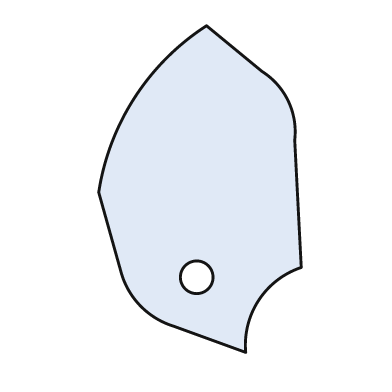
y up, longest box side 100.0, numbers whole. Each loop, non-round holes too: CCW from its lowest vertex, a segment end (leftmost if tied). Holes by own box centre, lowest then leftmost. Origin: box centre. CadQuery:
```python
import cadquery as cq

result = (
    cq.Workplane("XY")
    .moveTo(14.0, -50.0)
    .threePointArc((18.0, -34.0), (31.0, -24.0))
    .lineTo(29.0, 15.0)
    .threePointArc((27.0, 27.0), (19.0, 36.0))
    .lineTo(2.0, 50.0)
    .threePointArc((-20.0, 28.0), (-31.0, -1.0))
    .lineTo(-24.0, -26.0)
    .threePointArc((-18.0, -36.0), (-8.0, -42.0))
    .close()
    .moveTo(-1.0, -27.0)
    .circle(5.0)
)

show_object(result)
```